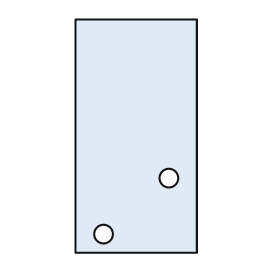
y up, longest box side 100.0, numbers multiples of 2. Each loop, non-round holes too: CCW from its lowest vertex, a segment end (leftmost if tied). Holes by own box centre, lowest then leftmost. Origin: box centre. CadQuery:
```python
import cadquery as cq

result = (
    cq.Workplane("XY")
    .moveTo(-26.0, -50.0)
    .lineTo(26.0, -50.0)
    .lineTo(26.0, 50.0)
    .lineTo(-26.0, 50.0)
    .close()
    .moveTo(-14.0, -42.0)
    .circle(4.0)
    .moveTo(14.0, -18.0)
    .circle(4.0)
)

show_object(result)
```